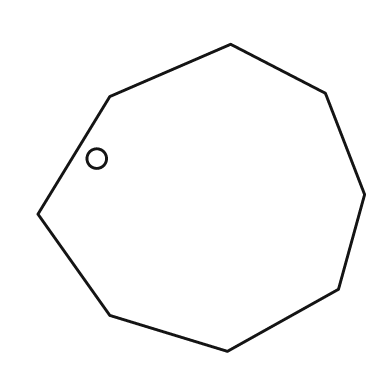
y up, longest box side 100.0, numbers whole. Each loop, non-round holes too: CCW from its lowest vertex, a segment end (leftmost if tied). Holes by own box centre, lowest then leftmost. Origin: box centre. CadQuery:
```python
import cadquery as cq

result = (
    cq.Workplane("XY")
    .moveTo(8.0, -47.0)
    .lineTo(42.0, -28.0)
    .lineTo(50.0, 1.0)
    .lineTo(38.0, 32.0)
    .lineTo(9.0, 47.0)
    .lineTo(-28.0, 31.0)
    .lineTo(-50.0, -5.0)
    .lineTo(-28.0, -36.0)
    .close()
    .moveTo(-32.0, 12.0)
    .circle(3.0)
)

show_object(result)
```